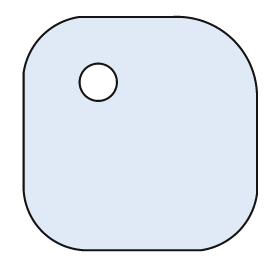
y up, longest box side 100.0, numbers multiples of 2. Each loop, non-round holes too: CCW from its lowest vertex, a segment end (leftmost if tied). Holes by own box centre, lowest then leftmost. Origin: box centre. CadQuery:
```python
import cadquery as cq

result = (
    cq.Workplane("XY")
    .moveTo(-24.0, -50.0)
    .lineTo(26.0, -50.0)
    .threePointArc((42.0, -42.0), (50.0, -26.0))
    .lineTo(50.0, 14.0)
    .threePointArc((40.0, 40.0), (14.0, 50.0))
    .lineTo(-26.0, 50.0)
    .threePointArc((-42.0, 42.0), (-50.0, 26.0))
    .lineTo(-50.0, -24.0)
    .threePointArc((-42.0, -42.0), (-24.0, -50.0))
    .close()
    .moveTo(-18.0, 22.0)
    .circle(8.0)
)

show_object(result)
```